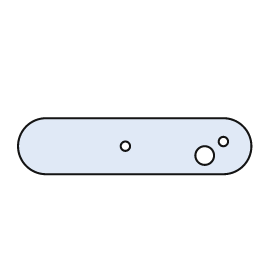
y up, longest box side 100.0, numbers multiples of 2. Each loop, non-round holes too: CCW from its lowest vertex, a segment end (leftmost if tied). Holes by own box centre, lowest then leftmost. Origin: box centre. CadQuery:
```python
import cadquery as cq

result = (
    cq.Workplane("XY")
    .moveTo(-38.0, -12.0)
    .lineTo(38.0, -12.0)
    .threePointArc((50.0, 0.0), (38.0, 12.0))
    .lineTo(-38.0, 12.0)
    .threePointArc((-50.0, 0.0), (-38.0, -12.0))
    .close()
    .moveTo(30.0, -4.0)
    .circle(4.0)
    .moveTo(-4.0, 0.0)
    .circle(2.0)
    .moveTo(38.0, 2.0)
    .circle(2.0)
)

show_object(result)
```